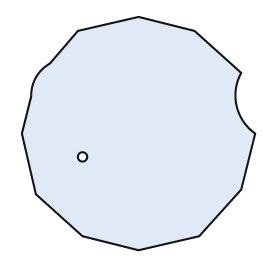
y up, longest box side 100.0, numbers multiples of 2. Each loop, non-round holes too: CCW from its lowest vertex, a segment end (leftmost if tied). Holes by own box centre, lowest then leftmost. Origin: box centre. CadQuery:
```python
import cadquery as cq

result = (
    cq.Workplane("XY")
    .moveTo(0.0, -50.0)
    .lineTo(26.0, -44.0)
    .lineTo(44.0, -24.0)
    .lineTo(50.0, 0.0)
    .threePointArc((42.0, 12.0), (44.0, 26.0))
    .lineTo(24.0, 44.0)
    .lineTo(0.0, 50.0)
    .lineTo(-26.0, 44.0)
    .lineTo(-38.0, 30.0)
    .threePointArc((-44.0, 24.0), (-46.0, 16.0))
    .lineTo(-50.0, 0.0)
    .lineTo(-44.0, -26.0)
    .lineTo(-24.0, -44.0)
    .close()
    .moveTo(-24.0, -10.0)
    .circle(2.0)
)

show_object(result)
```